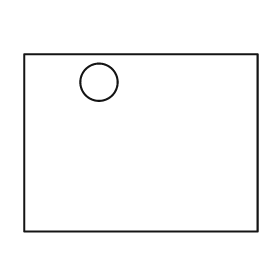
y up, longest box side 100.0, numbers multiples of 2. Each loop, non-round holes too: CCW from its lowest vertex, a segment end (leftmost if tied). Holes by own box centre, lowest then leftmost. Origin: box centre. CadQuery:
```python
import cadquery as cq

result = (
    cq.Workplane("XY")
    .moveTo(-50.0, -38.0)
    .lineTo(50.0, -38.0)
    .lineTo(50.0, 38.0)
    .lineTo(-50.0, 38.0)
    .close()
    .moveTo(-18.0, 26.0)
    .circle(8.0)
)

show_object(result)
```